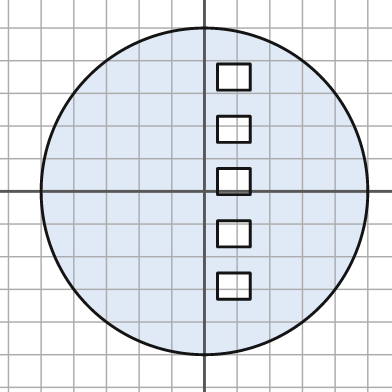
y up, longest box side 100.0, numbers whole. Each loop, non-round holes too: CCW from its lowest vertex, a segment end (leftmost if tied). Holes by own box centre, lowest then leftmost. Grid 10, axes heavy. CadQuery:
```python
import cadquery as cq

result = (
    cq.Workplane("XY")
    .moveTo(0.0, 0.0)
    .circle(50.0)
    .moveTo(4.0, -33.0)
    .lineTo(14.0, -33.0)
    .lineTo(14.0, -25.0)
    .lineTo(4.0, -25.0)
    .close()
    .moveTo(4.0, -17.0)
    .lineTo(14.0, -17.0)
    .lineTo(14.0, -9.0)
    .lineTo(4.0, -9.0)
    .close()
    .moveTo(4.0, -1.0)
    .lineTo(14.0, -1.0)
    .lineTo(14.0, 7.0)
    .lineTo(4.0, 7.0)
    .close()
    .moveTo(4.0, 15.0)
    .lineTo(14.0, 15.0)
    .lineTo(14.0, 23.0)
    .lineTo(4.0, 23.0)
    .close()
    .moveTo(4.0, 31.0)
    .lineTo(14.0, 31.0)
    .lineTo(14.0, 39.0)
    .lineTo(4.0, 39.0)
    .close()
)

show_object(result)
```